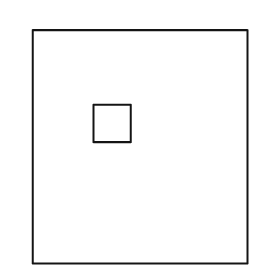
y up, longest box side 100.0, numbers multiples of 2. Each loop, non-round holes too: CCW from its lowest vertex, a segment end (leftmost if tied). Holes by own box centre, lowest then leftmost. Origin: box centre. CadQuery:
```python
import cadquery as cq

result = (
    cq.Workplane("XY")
    .moveTo(-46.0, -50.0)
    .lineTo(46.0, -50.0)
    .lineTo(46.0, 50.0)
    .lineTo(-46.0, 50.0)
    .close()
    .moveTo(-20.0, 2.0)
    .lineTo(-4.0, 2.0)
    .lineTo(-4.0, 18.0)
    .lineTo(-20.0, 18.0)
    .close()
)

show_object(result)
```